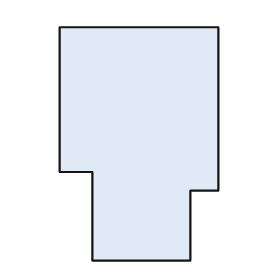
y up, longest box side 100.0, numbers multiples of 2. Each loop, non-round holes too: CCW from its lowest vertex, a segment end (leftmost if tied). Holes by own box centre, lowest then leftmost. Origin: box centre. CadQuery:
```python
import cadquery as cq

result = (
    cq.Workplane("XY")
    .moveTo(-20.0, -50.0)
    .lineTo(22.0, -50.0)
    .lineTo(22.0, -20.0)
    .lineTo(34.0, -20.0)
    .lineTo(34.0, 50.0)
    .lineTo(-34.0, 50.0)
    .lineTo(-34.0, -12.0)
    .lineTo(-20.0, -12.0)
    .close()
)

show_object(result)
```